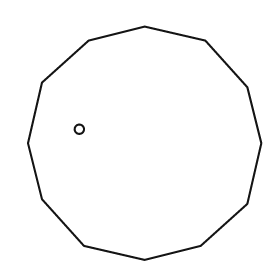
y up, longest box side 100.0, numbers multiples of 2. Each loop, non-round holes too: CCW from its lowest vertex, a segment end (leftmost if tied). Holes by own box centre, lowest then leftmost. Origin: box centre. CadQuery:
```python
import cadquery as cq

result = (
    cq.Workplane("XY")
    .moveTo(0.0, -50.0)
    .lineTo(24.0, -44.0)
    .lineTo(44.0, -26.0)
    .lineTo(50.0, 0.0)
    .lineTo(44.0, 24.0)
    .lineTo(26.0, 44.0)
    .lineTo(0.0, 50.0)
    .lineTo(-24.0, 44.0)
    .lineTo(-44.0, 26.0)
    .lineTo(-50.0, 0.0)
    .lineTo(-44.0, -24.0)
    .lineTo(-26.0, -44.0)
    .close()
    .moveTo(-28.0, 6.0)
    .circle(2.0)
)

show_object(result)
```